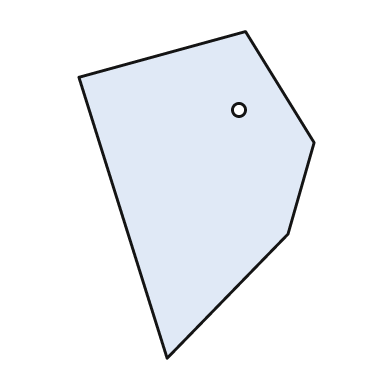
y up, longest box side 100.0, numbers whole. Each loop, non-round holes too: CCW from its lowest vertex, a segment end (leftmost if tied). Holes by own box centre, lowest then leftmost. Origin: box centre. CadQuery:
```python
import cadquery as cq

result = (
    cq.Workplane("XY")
    .moveTo(-9.0, -50.0)
    .lineTo(28.0, -12.0)
    .lineTo(36.0, 16.0)
    .lineTo(15.0, 50.0)
    .lineTo(-36.0, 36.0)
    .close()
    .moveTo(13.0, 26.0)
    .circle(2.0)
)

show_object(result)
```